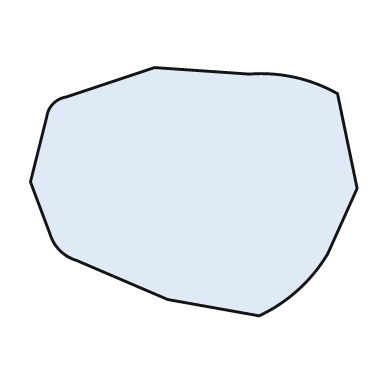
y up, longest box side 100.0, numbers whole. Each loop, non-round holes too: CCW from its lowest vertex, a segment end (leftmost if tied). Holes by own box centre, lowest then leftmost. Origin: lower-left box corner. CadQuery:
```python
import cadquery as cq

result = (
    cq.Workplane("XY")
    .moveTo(70.0, 0.0)
    .threePointArc((82.0, 8.0), (91.0, 19.0))
    .lineTo(100.0, 39.0)
    .lineTo(94.0, 68.0)
    .threePointArc((81.0, 73.0), (67.0, 74.0))
    .lineTo(38.0, 76.0)
    .lineTo(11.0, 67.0)
    .threePointArc((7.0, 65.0), (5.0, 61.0))
    .lineTo(0.0, 41.0)
    .lineTo(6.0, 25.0)
    .threePointArc((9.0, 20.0), (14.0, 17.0))
    .lineTo(42.0, 5.0)
    .close()
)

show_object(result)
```